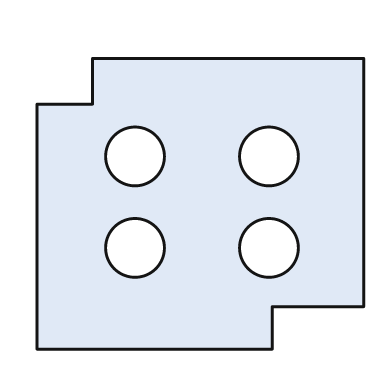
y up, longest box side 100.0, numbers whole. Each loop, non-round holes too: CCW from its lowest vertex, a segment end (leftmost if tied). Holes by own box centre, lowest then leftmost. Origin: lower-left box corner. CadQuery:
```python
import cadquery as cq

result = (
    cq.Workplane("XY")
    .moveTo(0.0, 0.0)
    .lineTo(72.0, 0.0)
    .lineTo(72.0, 13.0)
    .lineTo(100.0, 13.0)
    .lineTo(100.0, 89.0)
    .lineTo(17.0, 89.0)
    .lineTo(17.0, 75.0)
    .lineTo(0.0, 75.0)
    .close()
    .moveTo(30.0, 31.0)
    .circle(9.0)
    .moveTo(71.0, 31.0)
    .circle(9.0)
    .moveTo(30.0, 59.0)
    .circle(9.0)
    .moveTo(71.0, 59.0)
    .circle(9.0)
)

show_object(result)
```